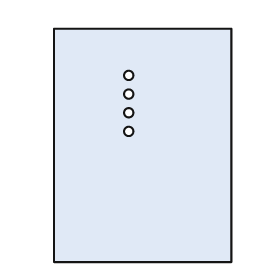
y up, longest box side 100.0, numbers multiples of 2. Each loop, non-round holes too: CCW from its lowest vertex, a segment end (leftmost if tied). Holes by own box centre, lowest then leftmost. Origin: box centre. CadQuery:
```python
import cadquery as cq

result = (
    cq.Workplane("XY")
    .moveTo(-38.0, -50.0)
    .lineTo(38.0, -50.0)
    .lineTo(38.0, 50.0)
    .lineTo(-38.0, 50.0)
    .close()
    .moveTo(-6.0, 6.0)
    .circle(2.0)
    .moveTo(-6.0, 14.0)
    .circle(2.0)
    .moveTo(-6.0, 22.0)
    .circle(2.0)
    .moveTo(-6.0, 30.0)
    .circle(2.0)
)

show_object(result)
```